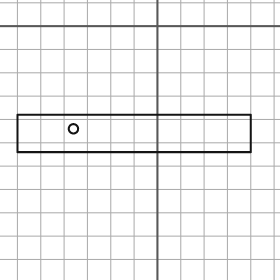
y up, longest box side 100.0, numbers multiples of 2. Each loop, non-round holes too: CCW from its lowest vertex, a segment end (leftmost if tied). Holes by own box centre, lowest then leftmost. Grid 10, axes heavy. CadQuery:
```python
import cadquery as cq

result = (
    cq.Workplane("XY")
    .moveTo(-60.0, -54.0)
    .lineTo(40.0, -54.0)
    .lineTo(40.0, -38.0)
    .lineTo(-60.0, -38.0)
    .close()
    .moveTo(-36.0, -44.0)
    .circle(2.0)
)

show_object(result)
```